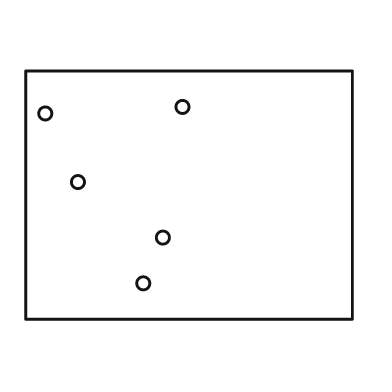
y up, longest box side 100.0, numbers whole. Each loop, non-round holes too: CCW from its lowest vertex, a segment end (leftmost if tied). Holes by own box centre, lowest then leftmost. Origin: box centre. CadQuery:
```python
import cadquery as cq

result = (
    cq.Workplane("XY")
    .moveTo(-50.0, -38.0)
    .lineTo(50.0, -38.0)
    .lineTo(50.0, 38.0)
    .lineTo(-50.0, 38.0)
    .close()
    .moveTo(-14.0, -27.0)
    .circle(2.0)
    .moveTo(-8.0, -13.0)
    .circle(2.0)
    .moveTo(-34.0, 4.0)
    .circle(2.0)
    .moveTo(-44.0, 25.0)
    .circle(2.0)
    .moveTo(-2.0, 27.0)
    .circle(2.0)
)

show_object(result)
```